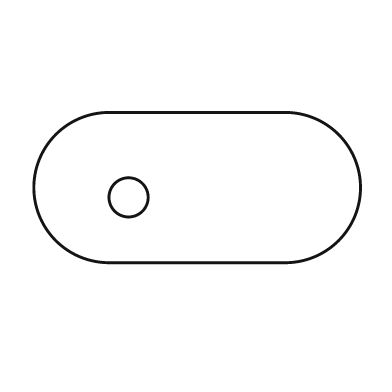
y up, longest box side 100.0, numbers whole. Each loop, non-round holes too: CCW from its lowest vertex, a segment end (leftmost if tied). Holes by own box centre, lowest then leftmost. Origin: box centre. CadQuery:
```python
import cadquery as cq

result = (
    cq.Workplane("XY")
    .moveTo(-27.0, -23.0)
    .lineTo(27.0, -23.0)
    .threePointArc((50.0, 0.0), (27.0, 23.0))
    .lineTo(-27.0, 23.0)
    .threePointArc((-50.0, 0.0), (-27.0, -23.0))
    .close()
    .moveTo(-21.0, -3.0)
    .circle(6.0)
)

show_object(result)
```